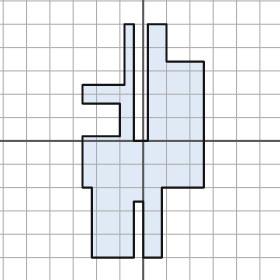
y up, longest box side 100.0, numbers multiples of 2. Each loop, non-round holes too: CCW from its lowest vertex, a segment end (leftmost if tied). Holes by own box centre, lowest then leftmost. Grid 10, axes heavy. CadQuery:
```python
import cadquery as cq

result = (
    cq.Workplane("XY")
    .moveTo(-22.0, -50.0)
    .lineTo(-4.0, -50.0)
    .lineTo(-4.0, -26.0)
    .lineTo(0.0, -26.0)
    .lineTo(0.0, -50.0)
    .lineTo(8.0, -50.0)
    .lineTo(8.0, -20.0)
    .lineTo(26.0, -20.0)
    .lineTo(26.0, 34.0)
    .lineTo(10.0, 34.0)
    .lineTo(10.0, 50.0)
    .lineTo(2.0, 50.0)
    .lineTo(2.0, 0.0)
    .lineTo(-4.0, 0.0)
    .lineTo(-4.0, 50.0)
    .lineTo(-8.0, 50.0)
    .lineTo(-8.0, 24.0)
    .lineTo(-26.0, 24.0)
    .lineTo(-26.0, 16.0)
    .lineTo(-10.0, 16.0)
    .lineTo(-10.0, 2.0)
    .lineTo(-26.0, 2.0)
    .lineTo(-26.0, -20.0)
    .lineTo(-22.0, -20.0)
    .close()
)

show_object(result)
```